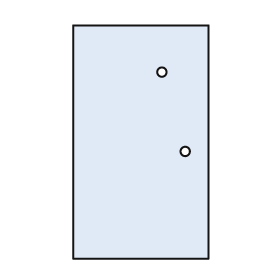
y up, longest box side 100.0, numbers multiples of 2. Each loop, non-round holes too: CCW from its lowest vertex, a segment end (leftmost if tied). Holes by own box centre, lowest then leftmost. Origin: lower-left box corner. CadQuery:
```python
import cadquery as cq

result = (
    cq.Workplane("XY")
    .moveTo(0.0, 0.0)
    .lineTo(58.0, 0.0)
    .lineTo(58.0, 100.0)
    .lineTo(0.0, 100.0)
    .close()
    .moveTo(48.0, 46.0)
    .circle(2.0)
    .moveTo(38.0, 80.0)
    .circle(2.0)
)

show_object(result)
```